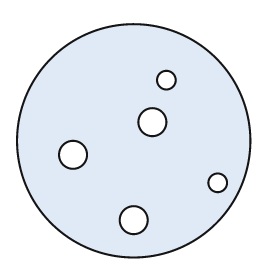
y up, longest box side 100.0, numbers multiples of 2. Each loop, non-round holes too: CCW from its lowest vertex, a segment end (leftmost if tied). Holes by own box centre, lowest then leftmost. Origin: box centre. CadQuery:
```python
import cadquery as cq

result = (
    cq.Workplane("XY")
    .moveTo(0.0, 0.0)
    .circle(50.0)
    .moveTo(0.0, -34.0)
    .circle(6.0)
    .moveTo(36.0, -18.0)
    .circle(4.0)
    .moveTo(-26.0, -6.0)
    .circle(6.0)
    .moveTo(8.0, 8.0)
    .circle(6.0)
    .moveTo(14.0, 26.0)
    .circle(4.0)
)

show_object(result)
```